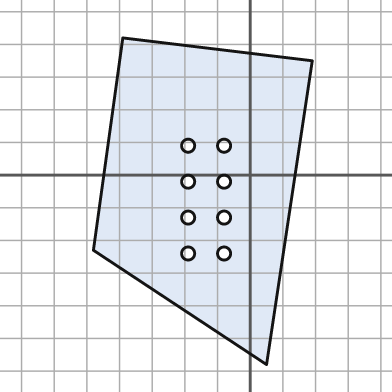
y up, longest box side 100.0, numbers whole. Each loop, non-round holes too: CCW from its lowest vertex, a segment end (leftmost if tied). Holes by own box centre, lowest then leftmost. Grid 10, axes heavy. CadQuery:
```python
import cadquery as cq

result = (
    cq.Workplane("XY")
    .moveTo(5.0, -58.0)
    .lineTo(19.0, 35.0)
    .lineTo(-39.0, 42.0)
    .lineTo(-48.0, -23.0)
    .close()
    .moveTo(-19.0, -24.0)
    .circle(2.0)
    .moveTo(-8.0, -24.0)
    .circle(2.0)
    .moveTo(-19.0, -13.0)
    .circle(2.0)
    .moveTo(-8.0, -13.0)
    .circle(2.0)
    .moveTo(-19.0, -2.0)
    .circle(2.0)
    .moveTo(-8.0, -2.0)
    .circle(2.0)
    .moveTo(-19.0, 9.0)
    .circle(2.0)
    .moveTo(-8.0, 9.0)
    .circle(2.0)
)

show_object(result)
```